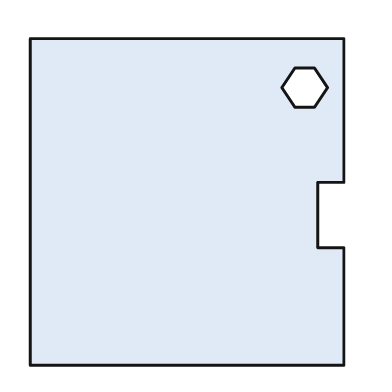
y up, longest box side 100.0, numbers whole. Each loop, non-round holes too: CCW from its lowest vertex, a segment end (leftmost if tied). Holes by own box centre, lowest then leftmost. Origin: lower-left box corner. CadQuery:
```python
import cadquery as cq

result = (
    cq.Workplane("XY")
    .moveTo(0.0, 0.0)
    .lineTo(96.0, 0.0)
    .lineTo(96.0, 36.0)
    .lineTo(88.0, 36.0)
    .lineTo(88.0, 56.0)
    .lineTo(96.0, 56.0)
    .lineTo(96.0, 100.0)
    .lineTo(0.0, 100.0)
    .close()
    .moveTo(81.0, 79.0)
    .lineTo(87.0, 79.0)
    .lineTo(91.0, 85.0)
    .lineTo(87.0, 91.0)
    .lineTo(81.0, 91.0)
    .lineTo(77.0, 85.0)
    .close()
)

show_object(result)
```